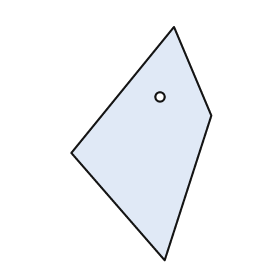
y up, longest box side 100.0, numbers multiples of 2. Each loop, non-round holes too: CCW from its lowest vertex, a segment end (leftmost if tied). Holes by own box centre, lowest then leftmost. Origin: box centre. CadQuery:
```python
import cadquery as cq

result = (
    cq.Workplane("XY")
    .moveTo(10.0, -50.0)
    .lineTo(30.0, 12.0)
    .lineTo(14.0, 50.0)
    .lineTo(-30.0, -4.0)
    .close()
    .moveTo(8.0, 20.0)
    .circle(2.0)
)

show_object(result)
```